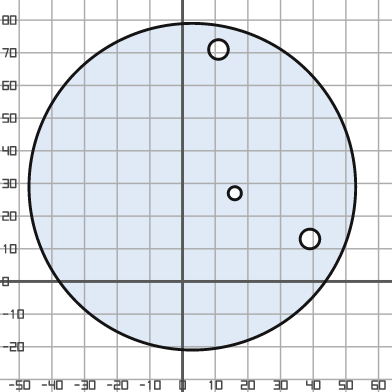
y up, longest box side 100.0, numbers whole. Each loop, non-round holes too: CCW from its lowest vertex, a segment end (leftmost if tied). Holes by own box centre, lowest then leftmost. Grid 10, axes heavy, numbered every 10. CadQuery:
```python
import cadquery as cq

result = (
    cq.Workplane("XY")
    .moveTo(3.0, 29.0)
    .circle(50.0)
    .moveTo(39.0, 13.0)
    .circle(3.0)
    .moveTo(16.0, 27.0)
    .circle(2.0)
    .moveTo(11.0, 71.0)
    .circle(3.0)
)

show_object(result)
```